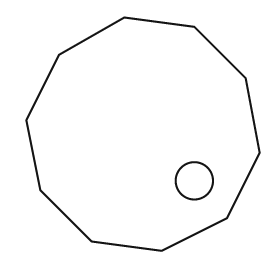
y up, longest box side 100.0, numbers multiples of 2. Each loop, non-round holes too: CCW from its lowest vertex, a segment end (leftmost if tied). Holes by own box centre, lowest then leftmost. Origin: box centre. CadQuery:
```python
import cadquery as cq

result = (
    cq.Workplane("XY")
    .moveTo(8.0, -50.0)
    .lineTo(36.0, -36.0)
    .lineTo(50.0, -8.0)
    .lineTo(44.0, 24.0)
    .lineTo(22.0, 46.0)
    .lineTo(-8.0, 50.0)
    .lineTo(-36.0, 34.0)
    .lineTo(-50.0, 6.0)
    .lineTo(-44.0, -24.0)
    .lineTo(-22.0, -46.0)
    .close()
    .moveTo(22.0, -20.0)
    .circle(8.0)
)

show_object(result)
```